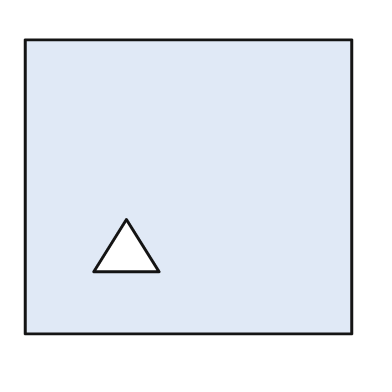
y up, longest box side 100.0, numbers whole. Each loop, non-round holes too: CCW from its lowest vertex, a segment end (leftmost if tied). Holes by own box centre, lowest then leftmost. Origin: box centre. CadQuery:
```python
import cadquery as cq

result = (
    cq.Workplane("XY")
    .moveTo(-50.0, -45.0)
    .lineTo(50.0, -45.0)
    .lineTo(50.0, 45.0)
    .lineTo(-50.0, 45.0)
    .close()
    .moveTo(-29.0, -26.0)
    .lineTo(-9.0, -26.0)
    .lineTo(-19.0, -10.0)
    .close()
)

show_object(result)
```